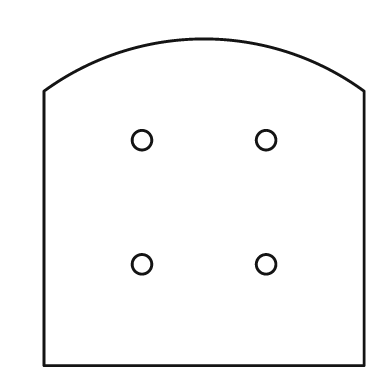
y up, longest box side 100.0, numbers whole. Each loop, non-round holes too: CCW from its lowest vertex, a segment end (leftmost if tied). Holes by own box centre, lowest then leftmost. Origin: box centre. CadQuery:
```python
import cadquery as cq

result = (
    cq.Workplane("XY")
    .moveTo(-49.0, -50.0)
    .lineTo(49.0, -50.0)
    .lineTo(49.0, 34.0)
    .threePointArc((0.0, 50.0), (-49.0, 34.0))
    .close()
    .moveTo(-19.0, -19.0)
    .circle(3.0)
    .moveTo(19.0, -19.0)
    .circle(3.0)
    .moveTo(-19.0, 19.0)
    .circle(3.0)
    .moveTo(19.0, 19.0)
    .circle(3.0)
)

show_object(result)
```